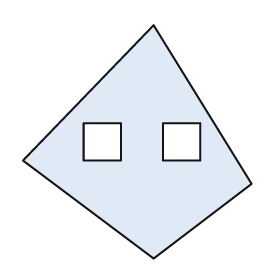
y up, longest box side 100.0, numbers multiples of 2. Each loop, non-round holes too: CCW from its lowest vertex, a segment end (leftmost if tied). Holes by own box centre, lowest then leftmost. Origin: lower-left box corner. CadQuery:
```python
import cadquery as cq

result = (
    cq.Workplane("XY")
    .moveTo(56.0, 0.0)
    .lineTo(98.0, 32.0)
    .lineTo(56.0, 100.0)
    .lineTo(0.0, 42.0)
    .close()
    .moveTo(26.0, 42.0)
    .lineTo(42.0, 42.0)
    .lineTo(42.0, 58.0)
    .lineTo(26.0, 58.0)
    .close()
    .moveTo(60.0, 42.0)
    .lineTo(76.0, 42.0)
    .lineTo(76.0, 58.0)
    .lineTo(60.0, 58.0)
    .close()
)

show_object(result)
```